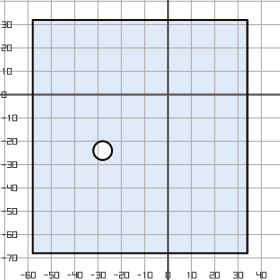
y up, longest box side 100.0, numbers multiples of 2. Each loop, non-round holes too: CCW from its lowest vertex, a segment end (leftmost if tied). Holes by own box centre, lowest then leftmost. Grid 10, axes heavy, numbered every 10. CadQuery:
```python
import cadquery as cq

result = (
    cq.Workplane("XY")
    .moveTo(-58.0, -68.0)
    .lineTo(34.0, -68.0)
    .lineTo(34.0, 32.0)
    .lineTo(-58.0, 32.0)
    .close()
    .moveTo(-28.0, -24.0)
    .circle(4.0)
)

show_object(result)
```